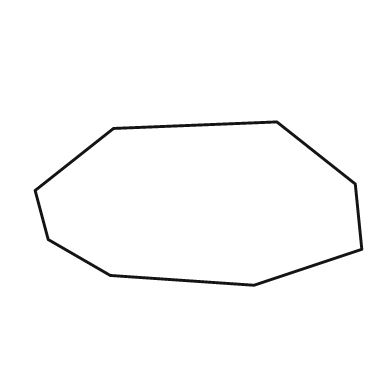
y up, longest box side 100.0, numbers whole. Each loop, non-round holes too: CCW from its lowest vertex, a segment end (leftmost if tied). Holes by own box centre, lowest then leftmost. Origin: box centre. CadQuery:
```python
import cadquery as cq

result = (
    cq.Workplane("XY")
    .moveTo(17.0, -25.0)
    .lineTo(50.0, -14.0)
    .lineTo(48.0, 6.0)
    .lineTo(24.0, 25.0)
    .lineTo(-26.0, 23.0)
    .lineTo(-50.0, 4.0)
    .lineTo(-46.0, -11.0)
    .lineTo(-27.0, -22.0)
    .close()
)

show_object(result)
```